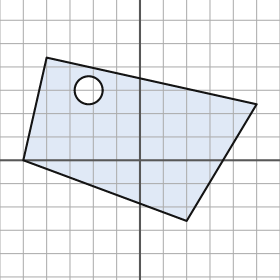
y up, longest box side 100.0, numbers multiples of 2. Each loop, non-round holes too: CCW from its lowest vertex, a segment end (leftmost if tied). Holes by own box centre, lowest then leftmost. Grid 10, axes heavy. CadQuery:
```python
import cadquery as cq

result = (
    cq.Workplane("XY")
    .moveTo(20.0, -26.0)
    .lineTo(50.0, 24.0)
    .lineTo(-40.0, 44.0)
    .lineTo(-50.0, 0.0)
    .close()
    .moveTo(-22.0, 30.0)
    .circle(6.0)
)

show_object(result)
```